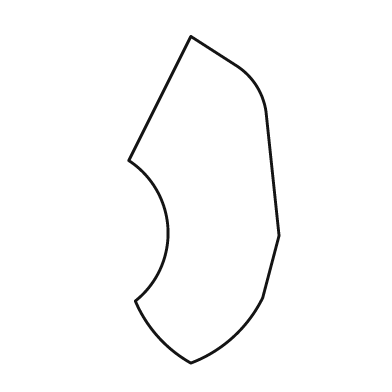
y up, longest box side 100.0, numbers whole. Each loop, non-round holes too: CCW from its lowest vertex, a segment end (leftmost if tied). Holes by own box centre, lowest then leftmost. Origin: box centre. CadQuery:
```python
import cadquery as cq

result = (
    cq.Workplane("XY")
    .moveTo(-4.0, -50.0)
    .threePointArc((9.0, -42.0), (18.0, -30.0))
    .lineTo(23.0, -11.0)
    .lineTo(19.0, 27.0)
    .threePointArc((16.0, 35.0), (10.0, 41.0))
    .lineTo(-4.0, 50.0)
    .lineTo(-23.0, 12.0)
    .threePointArc((-11.0, -9.0), (-21.0, -31.0))
    .threePointArc((-14.0, -42.0), (-4.0, -50.0))
    .close()
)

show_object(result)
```